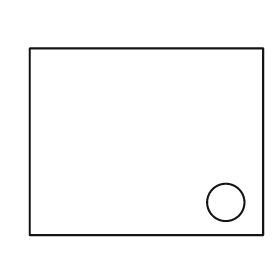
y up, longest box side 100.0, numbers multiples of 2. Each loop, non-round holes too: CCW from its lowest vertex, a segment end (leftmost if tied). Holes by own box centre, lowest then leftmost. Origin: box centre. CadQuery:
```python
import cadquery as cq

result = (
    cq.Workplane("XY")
    .moveTo(-50.0, -40.0)
    .lineTo(50.0, -40.0)
    .lineTo(50.0, 40.0)
    .lineTo(-50.0, 40.0)
    .close()
    .moveTo(34.0, -26.0)
    .circle(8.0)
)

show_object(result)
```